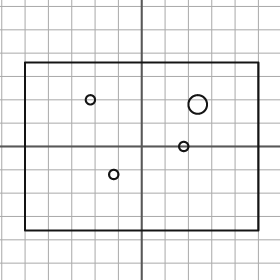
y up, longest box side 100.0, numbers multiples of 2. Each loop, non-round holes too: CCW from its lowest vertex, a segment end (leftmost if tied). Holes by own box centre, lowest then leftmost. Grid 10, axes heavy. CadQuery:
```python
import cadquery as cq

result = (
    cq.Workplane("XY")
    .moveTo(-50.0, -36.0)
    .lineTo(50.0, -36.0)
    .lineTo(50.0, 36.0)
    .lineTo(-50.0, 36.0)
    .close()
    .moveTo(-12.0, -12.0)
    .circle(2.0)
    .moveTo(18.0, 0.0)
    .circle(2.0)
    .moveTo(24.0, 18.0)
    .circle(4.0)
    .moveTo(-22.0, 20.0)
    .circle(2.0)
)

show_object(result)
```